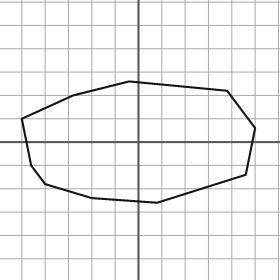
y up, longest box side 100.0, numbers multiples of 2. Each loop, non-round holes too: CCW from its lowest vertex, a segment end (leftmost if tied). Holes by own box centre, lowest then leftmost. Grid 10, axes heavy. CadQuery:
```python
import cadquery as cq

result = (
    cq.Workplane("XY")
    .moveTo(8.0, -26.0)
    .lineTo(46.0, -14.0)
    .lineTo(50.0, 6.0)
    .lineTo(38.0, 22.0)
    .lineTo(-4.0, 26.0)
    .lineTo(-28.0, 20.0)
    .lineTo(-50.0, 10.0)
    .lineTo(-46.0, -10.0)
    .lineTo(-40.0, -18.0)
    .lineTo(-20.0, -24.0)
    .close()
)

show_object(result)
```